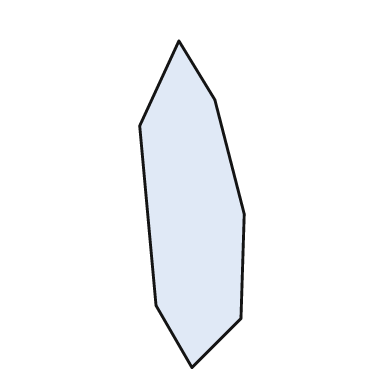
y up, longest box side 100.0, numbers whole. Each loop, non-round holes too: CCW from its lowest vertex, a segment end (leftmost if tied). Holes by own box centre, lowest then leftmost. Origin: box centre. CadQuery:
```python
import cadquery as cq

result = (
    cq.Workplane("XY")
    .moveTo(0.0, -50.0)
    .lineTo(15.0, -35.0)
    .lineTo(16.0, -3.0)
    .lineTo(7.0, 32.0)
    .lineTo(-4.0, 50.0)
    .lineTo(-16.0, 24.0)
    .lineTo(-11.0, -31.0)
    .close()
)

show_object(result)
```